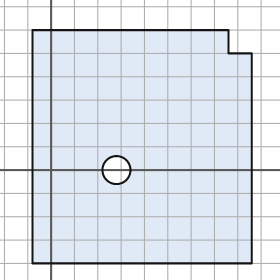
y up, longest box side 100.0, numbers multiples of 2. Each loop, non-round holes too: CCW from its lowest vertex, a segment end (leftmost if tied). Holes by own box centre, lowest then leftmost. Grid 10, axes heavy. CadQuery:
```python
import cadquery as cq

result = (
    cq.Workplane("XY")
    .moveTo(-8.0, -40.0)
    .lineTo(86.0, -40.0)
    .lineTo(86.0, 50.0)
    .lineTo(76.0, 50.0)
    .lineTo(76.0, 60.0)
    .lineTo(-8.0, 60.0)
    .close()
    .moveTo(28.0, 0.0)
    .circle(6.0)
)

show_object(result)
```